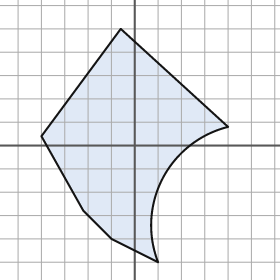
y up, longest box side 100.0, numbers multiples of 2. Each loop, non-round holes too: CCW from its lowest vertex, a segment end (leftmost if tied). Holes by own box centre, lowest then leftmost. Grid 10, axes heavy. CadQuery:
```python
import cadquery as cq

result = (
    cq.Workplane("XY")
    .moveTo(10.0, -50.0)
    .threePointArc((12.0, -14.0), (40.0, 8.0))
    .lineTo(-6.0, 50.0)
    .lineTo(-40.0, 4.0)
    .lineTo(-22.0, -28.0)
    .lineTo(-10.0, -40.0)
    .close()
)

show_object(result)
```